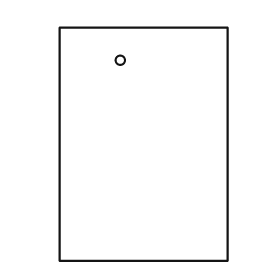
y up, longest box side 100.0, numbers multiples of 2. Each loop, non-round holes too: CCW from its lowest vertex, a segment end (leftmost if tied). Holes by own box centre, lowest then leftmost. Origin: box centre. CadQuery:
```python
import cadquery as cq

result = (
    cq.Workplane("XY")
    .moveTo(-36.0, -50.0)
    .lineTo(36.0, -50.0)
    .lineTo(36.0, 50.0)
    .lineTo(-36.0, 50.0)
    .close()
    .moveTo(-10.0, 36.0)
    .circle(2.0)
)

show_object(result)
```